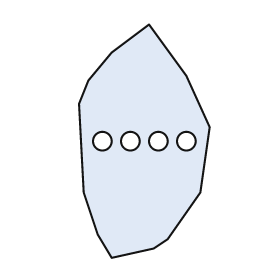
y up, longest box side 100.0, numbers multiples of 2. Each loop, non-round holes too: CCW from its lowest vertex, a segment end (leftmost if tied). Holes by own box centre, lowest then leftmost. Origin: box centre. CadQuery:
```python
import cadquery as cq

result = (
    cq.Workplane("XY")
    .moveTo(-14.0, -50.0)
    .lineTo(4.0, -46.0)
    .lineTo(10.0, -42.0)
    .lineTo(24.0, -22.0)
    .lineTo(28.0, 6.0)
    .lineTo(18.0, 28.0)
    .lineTo(2.0, 50.0)
    .lineTo(-14.0, 38.0)
    .lineTo(-24.0, 26.0)
    .lineTo(-28.0, 16.0)
    .lineTo(-26.0, -22.0)
    .lineTo(-20.0, -40.0)
    .close()
    .moveTo(-18.0, 0.0)
    .circle(4.0)
    .moveTo(-6.0, 0.0)
    .circle(4.0)
    .moveTo(6.0, 0.0)
    .circle(4.0)
    .moveTo(18.0, 0.0)
    .circle(4.0)
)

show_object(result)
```